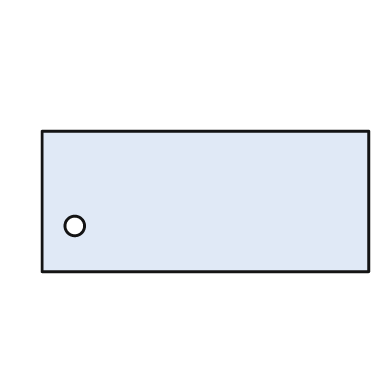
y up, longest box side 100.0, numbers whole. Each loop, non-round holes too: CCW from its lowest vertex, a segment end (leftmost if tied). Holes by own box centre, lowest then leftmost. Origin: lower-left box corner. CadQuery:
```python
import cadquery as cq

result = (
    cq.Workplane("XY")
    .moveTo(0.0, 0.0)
    .lineTo(100.0, 0.0)
    .lineTo(100.0, 43.0)
    .lineTo(0.0, 43.0)
    .close()
    .moveTo(10.0, 14.0)
    .circle(3.0)
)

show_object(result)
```